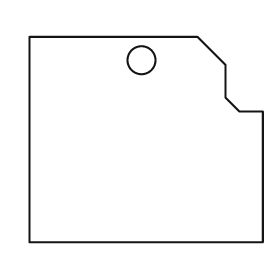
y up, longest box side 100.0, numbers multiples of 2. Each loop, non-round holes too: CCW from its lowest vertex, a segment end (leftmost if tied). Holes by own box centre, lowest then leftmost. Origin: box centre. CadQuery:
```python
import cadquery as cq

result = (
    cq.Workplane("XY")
    .moveTo(-50.0, -44.0)
    .lineTo(50.0, -44.0)
    .lineTo(50.0, 12.0)
    .lineTo(40.0, 12.0)
    .lineTo(34.0, 18.0)
    .lineTo(34.0, 32.0)
    .lineTo(22.0, 44.0)
    .lineTo(-50.0, 44.0)
    .close()
    .moveTo(-2.0, 34.0)
    .circle(6.0)
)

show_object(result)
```